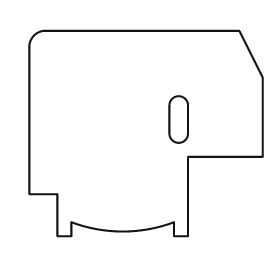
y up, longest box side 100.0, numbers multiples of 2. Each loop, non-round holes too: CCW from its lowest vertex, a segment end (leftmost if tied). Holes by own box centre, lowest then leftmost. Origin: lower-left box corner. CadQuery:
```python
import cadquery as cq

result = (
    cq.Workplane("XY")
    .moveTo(12.0, 0.0)
    .lineTo(18.0, 0.0)
    .lineTo(18.0, 6.0)
    .threePointArc((40.0, 2.0), (62.0, 6.0))
    .lineTo(62.0, 0.0)
    .lineTo(68.0, 0.0)
    .lineTo(68.0, 34.0)
    .lineTo(100.0, 34.0)
    .lineTo(100.0, 68.0)
    .lineTo(90.0, 88.0)
    .lineTo(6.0, 88.0)
    .threePointArc((2.0, 86.0), (0.0, 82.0))
    .lineTo(0.0, 18.0)
    .lineTo(12.0, 18.0)
    .close()
    .moveTo(60.0, 44.0)
    .threePointArc((64.0, 40.0), (68.0, 44.0))
    .lineTo(68.0, 56.0)
    .threePointArc((64.0, 60.0), (60.0, 56.0))
    .close()
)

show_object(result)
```